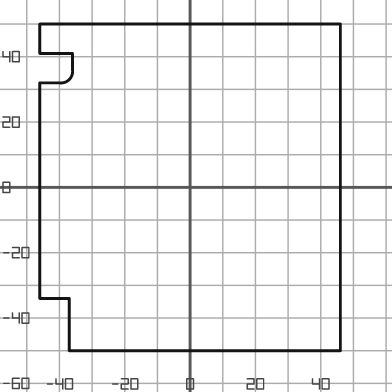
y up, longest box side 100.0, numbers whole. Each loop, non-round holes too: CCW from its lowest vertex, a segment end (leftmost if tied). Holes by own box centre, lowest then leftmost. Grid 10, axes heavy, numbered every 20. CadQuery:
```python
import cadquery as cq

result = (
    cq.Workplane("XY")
    .moveTo(-37.0, -50.0)
    .lineTo(46.0, -50.0)
    .lineTo(46.0, 50.0)
    .lineTo(-46.0, 50.0)
    .lineTo(-46.0, 41.0)
    .lineTo(-36.0, 41.0)
    .lineTo(-36.0, 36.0)
    .threePointArc((-37.0, 33.0), (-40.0, 32.0))
    .lineTo(-46.0, 32.0)
    .lineTo(-46.0, -34.0)
    .lineTo(-37.0, -34.0)
    .close()
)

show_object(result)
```